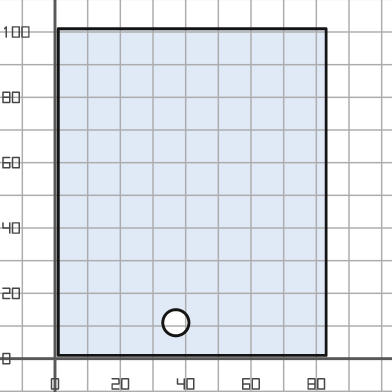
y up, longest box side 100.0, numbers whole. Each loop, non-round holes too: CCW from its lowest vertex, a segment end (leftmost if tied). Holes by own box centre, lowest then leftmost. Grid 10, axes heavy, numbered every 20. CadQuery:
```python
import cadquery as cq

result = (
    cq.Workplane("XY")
    .moveTo(1.0, 1.0)
    .lineTo(83.0, 1.0)
    .lineTo(83.0, 101.0)
    .lineTo(1.0, 101.0)
    .close()
    .moveTo(37.0, 11.0)
    .circle(4.0)
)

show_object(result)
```